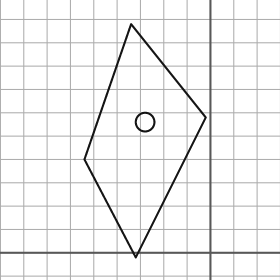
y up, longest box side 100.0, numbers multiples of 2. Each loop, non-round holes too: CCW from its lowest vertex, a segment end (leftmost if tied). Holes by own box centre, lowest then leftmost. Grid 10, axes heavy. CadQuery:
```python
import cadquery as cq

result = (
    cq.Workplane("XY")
    .moveTo(-32.0, -2.0)
    .lineTo(-2.0, 58.0)
    .lineTo(-34.0, 98.0)
    .lineTo(-54.0, 40.0)
    .close()
    .moveTo(-28.0, 56.0)
    .circle(4.0)
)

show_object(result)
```